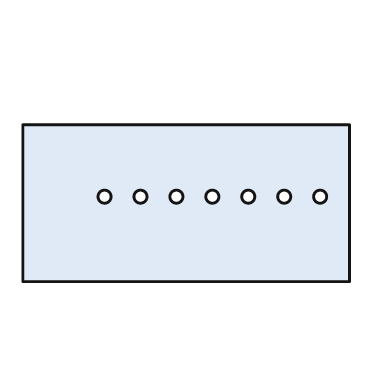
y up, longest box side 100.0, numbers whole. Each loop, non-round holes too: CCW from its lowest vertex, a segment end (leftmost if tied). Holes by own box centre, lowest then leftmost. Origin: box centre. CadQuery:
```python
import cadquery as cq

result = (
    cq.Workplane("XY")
    .moveTo(-50.0, -24.0)
    .lineTo(50.0, -24.0)
    .lineTo(50.0, 24.0)
    .lineTo(-50.0, 24.0)
    .close()
    .moveTo(-25.0, 2.0)
    .circle(2.0)
    .moveTo(-14.0, 2.0)
    .circle(2.0)
    .moveTo(-3.0, 2.0)
    .circle(2.0)
    .moveTo(8.0, 2.0)
    .circle(2.0)
    .moveTo(19.0, 2.0)
    .circle(2.0)
    .moveTo(30.0, 2.0)
    .circle(2.0)
    .moveTo(41.0, 2.0)
    .circle(2.0)
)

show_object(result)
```